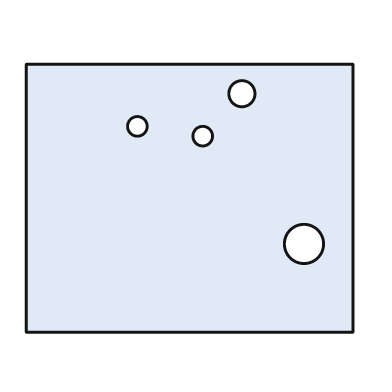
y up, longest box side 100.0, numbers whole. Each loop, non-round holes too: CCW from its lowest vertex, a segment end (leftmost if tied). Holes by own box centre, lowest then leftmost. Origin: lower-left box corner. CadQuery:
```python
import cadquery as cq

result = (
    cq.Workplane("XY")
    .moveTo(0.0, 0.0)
    .lineTo(100.0, 0.0)
    .lineTo(100.0, 82.0)
    .lineTo(0.0, 82.0)
    .close()
    .moveTo(85.0, 27.0)
    .circle(6.0)
    .moveTo(54.0, 60.0)
    .circle(3.0)
    .moveTo(34.0, 63.0)
    .circle(3.0)
    .moveTo(66.0, 73.0)
    .circle(4.0)
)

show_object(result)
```